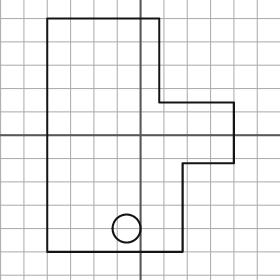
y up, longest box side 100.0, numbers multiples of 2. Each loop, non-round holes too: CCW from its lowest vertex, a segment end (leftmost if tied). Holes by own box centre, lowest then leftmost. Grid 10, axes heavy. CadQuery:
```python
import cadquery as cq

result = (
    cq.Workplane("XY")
    .moveTo(-40.0, -50.0)
    .lineTo(18.0, -50.0)
    .lineTo(18.0, -12.0)
    .lineTo(40.0, -12.0)
    .lineTo(40.0, 14.0)
    .lineTo(8.0, 14.0)
    .lineTo(8.0, 50.0)
    .lineTo(-40.0, 50.0)
    .close()
    .moveTo(-6.0, -40.0)
    .circle(6.0)
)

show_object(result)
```